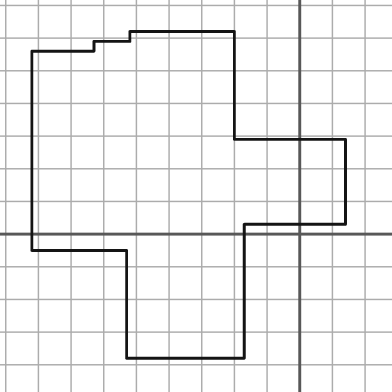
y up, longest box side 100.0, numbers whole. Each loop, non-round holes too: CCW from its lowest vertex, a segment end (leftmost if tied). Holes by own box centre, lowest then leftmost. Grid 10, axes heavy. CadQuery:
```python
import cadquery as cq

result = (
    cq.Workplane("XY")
    .moveTo(-53.0, -38.0)
    .lineTo(-17.0, -38.0)
    .lineTo(-17.0, 3.0)
    .lineTo(14.0, 3.0)
    .lineTo(14.0, 29.0)
    .lineTo(-20.0, 29.0)
    .lineTo(-20.0, 62.0)
    .lineTo(-52.0, 62.0)
    .lineTo(-52.0, 59.0)
    .lineTo(-63.0, 59.0)
    .lineTo(-63.0, 56.0)
    .lineTo(-82.0, 56.0)
    .lineTo(-82.0, -5.0)
    .lineTo(-53.0, -5.0)
    .close()
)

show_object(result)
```